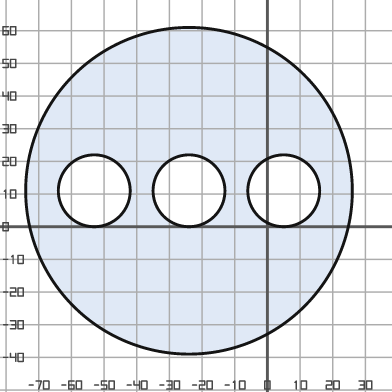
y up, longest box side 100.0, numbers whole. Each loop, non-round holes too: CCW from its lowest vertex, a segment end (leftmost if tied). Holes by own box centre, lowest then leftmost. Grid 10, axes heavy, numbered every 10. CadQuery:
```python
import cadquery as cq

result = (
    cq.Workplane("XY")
    .moveTo(-24.0, 11.0)
    .circle(50.0)
    .moveTo(-53.0, 11.0)
    .circle(11.0)
    .moveTo(-24.0, 11.0)
    .circle(11.0)
    .moveTo(5.0, 11.0)
    .circle(11.0)
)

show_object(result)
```